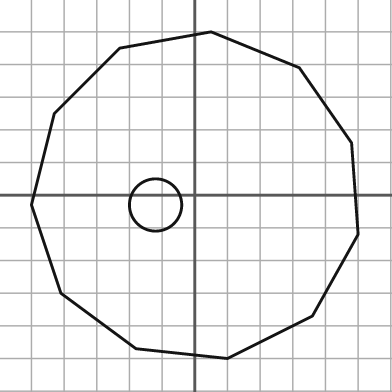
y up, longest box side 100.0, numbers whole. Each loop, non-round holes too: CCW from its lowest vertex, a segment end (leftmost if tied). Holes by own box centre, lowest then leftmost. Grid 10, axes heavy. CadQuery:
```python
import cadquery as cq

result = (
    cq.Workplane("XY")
    .moveTo(10.0, -50.0)
    .lineTo(36.0, -37.0)
    .lineTo(50.0, -12.0)
    .lineTo(48.0, 16.0)
    .lineTo(32.0, 39.0)
    .lineTo(5.0, 50.0)
    .lineTo(-23.0, 45.0)
    .lineTo(-43.0, 25.0)
    .lineTo(-50.0, -3.0)
    .lineTo(-41.0, -30.0)
    .lineTo(-18.0, -47.0)
    .close()
    .moveTo(-12.0, -3.0)
    .circle(8.0)
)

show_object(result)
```